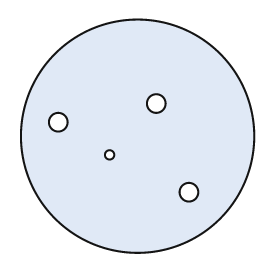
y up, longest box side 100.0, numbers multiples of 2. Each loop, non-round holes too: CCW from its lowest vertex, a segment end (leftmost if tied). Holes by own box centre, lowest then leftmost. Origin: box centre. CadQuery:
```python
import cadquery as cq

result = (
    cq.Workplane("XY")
    .moveTo(0.0, 0.0)
    .circle(50.0)
    .moveTo(22.0, -24.0)
    .circle(4.0)
    .moveTo(-12.0, -8.0)
    .circle(2.0)
    .moveTo(-34.0, 6.0)
    .circle(4.0)
    .moveTo(8.0, 14.0)
    .circle(4.0)
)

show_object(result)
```